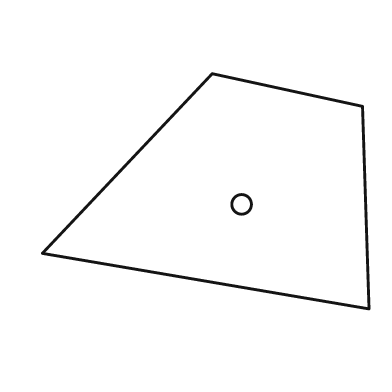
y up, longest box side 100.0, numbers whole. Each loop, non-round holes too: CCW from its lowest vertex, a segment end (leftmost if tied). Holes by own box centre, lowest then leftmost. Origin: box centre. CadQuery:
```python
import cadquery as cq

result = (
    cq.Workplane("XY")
    .moveTo(50.0, -36.0)
    .lineTo(48.0, 26.0)
    .lineTo(2.0, 36.0)
    .lineTo(-50.0, -19.0)
    .close()
    .moveTo(11.0, -4.0)
    .circle(3.0)
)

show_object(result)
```